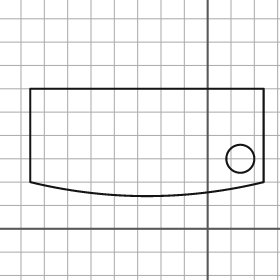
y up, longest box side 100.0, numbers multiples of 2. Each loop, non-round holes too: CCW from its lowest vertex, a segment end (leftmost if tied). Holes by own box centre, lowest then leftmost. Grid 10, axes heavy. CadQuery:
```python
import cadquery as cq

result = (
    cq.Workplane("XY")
    .moveTo(-76.0, 20.0)
    .threePointArc((-26.0, 14.0), (24.0, 20.0))
    .lineTo(24.0, 60.0)
    .lineTo(-76.0, 60.0)
    .close()
    .moveTo(14.0, 30.0)
    .circle(6.0)
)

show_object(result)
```